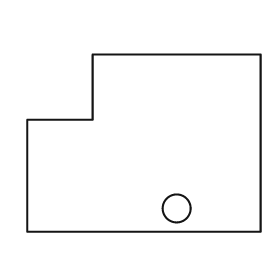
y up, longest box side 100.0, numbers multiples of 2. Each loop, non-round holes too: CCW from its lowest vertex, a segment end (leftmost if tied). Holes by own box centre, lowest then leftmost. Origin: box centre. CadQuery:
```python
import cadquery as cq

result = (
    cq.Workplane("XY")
    .moveTo(-50.0, -38.0)
    .lineTo(50.0, -38.0)
    .lineTo(50.0, 38.0)
    .lineTo(-22.0, 38.0)
    .lineTo(-22.0, 10.0)
    .lineTo(-50.0, 10.0)
    .close()
    .moveTo(14.0, -28.0)
    .circle(6.0)
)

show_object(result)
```